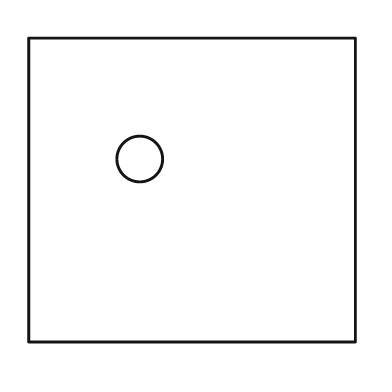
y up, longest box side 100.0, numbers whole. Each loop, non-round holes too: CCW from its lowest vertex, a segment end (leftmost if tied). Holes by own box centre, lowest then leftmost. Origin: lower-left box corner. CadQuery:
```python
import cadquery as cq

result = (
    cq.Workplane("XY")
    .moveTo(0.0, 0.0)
    .lineTo(100.0, 0.0)
    .lineTo(100.0, 93.0)
    .lineTo(0.0, 93.0)
    .close()
    .moveTo(34.0, 56.0)
    .circle(7.0)
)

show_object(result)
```